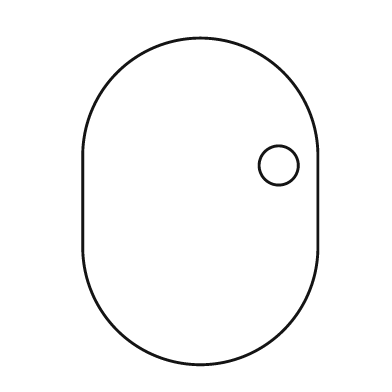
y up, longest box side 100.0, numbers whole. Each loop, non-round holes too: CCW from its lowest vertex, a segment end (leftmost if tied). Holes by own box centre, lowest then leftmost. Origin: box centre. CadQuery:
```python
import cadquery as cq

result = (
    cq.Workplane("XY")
    .moveTo(-36.0, -14.0)
    .threePointArc((0.0, -50.0), (36.0, -14.0))
    .lineTo(36.0, 14.0)
    .threePointArc((0.0, 50.0), (-36.0, 14.0))
    .close()
    .moveTo(24.0, 11.0)
    .circle(6.0)
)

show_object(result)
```